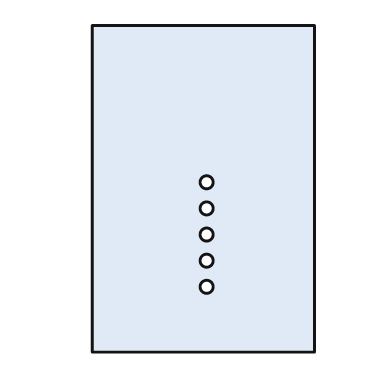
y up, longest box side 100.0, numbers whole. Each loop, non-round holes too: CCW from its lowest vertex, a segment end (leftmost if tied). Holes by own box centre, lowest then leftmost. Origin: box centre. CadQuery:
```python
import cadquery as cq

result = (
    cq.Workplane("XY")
    .moveTo(-34.0, -50.0)
    .lineTo(34.0, -50.0)
    .lineTo(34.0, 50.0)
    .lineTo(-34.0, 50.0)
    .close()
    .moveTo(1.0, -30.0)
    .circle(2.0)
    .moveTo(1.0, -22.0)
    .circle(2.0)
    .moveTo(1.0, -14.0)
    .circle(2.0)
    .moveTo(1.0, -6.0)
    .circle(2.0)
    .moveTo(1.0, 2.0)
    .circle(2.0)
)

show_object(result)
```